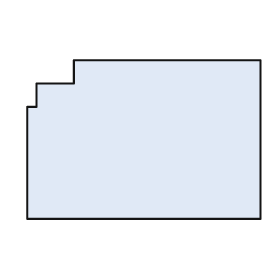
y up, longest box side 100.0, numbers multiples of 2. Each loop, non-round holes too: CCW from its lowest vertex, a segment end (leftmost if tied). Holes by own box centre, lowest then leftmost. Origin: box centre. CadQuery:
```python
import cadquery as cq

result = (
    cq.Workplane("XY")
    .moveTo(-50.0, -34.0)
    .lineTo(50.0, -34.0)
    .lineTo(50.0, 34.0)
    .lineTo(-30.0, 34.0)
    .lineTo(-30.0, 24.0)
    .lineTo(-46.0, 24.0)
    .lineTo(-46.0, 14.0)
    .lineTo(-50.0, 14.0)
    .close()
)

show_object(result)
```